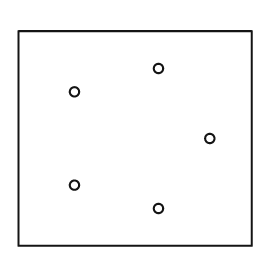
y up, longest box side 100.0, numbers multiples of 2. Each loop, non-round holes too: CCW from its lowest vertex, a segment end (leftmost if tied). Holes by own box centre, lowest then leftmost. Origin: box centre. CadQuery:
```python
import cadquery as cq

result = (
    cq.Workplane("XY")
    .moveTo(-50.0, -46.0)
    .lineTo(50.0, -46.0)
    .lineTo(50.0, 46.0)
    .lineTo(-50.0, 46.0)
    .close()
    .moveTo(10.0, -30.0)
    .circle(2.0)
    .moveTo(-26.0, -20.0)
    .circle(2.0)
    .moveTo(32.0, 0.0)
    .circle(2.0)
    .moveTo(-26.0, 20.0)
    .circle(2.0)
    .moveTo(10.0, 30.0)
    .circle(2.0)
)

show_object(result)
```